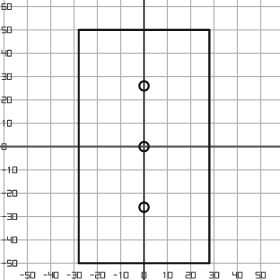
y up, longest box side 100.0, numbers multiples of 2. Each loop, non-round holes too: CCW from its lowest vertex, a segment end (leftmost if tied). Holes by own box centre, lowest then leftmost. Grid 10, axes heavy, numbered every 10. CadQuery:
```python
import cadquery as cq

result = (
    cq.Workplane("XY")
    .moveTo(-28.0, -50.0)
    .lineTo(28.0, -50.0)
    .lineTo(28.0, 50.0)
    .lineTo(-28.0, 50.0)
    .close()
    .moveTo(0.0, -26.0)
    .circle(2.0)
    .moveTo(0.0, 0.0)
    .circle(2.0)
    .moveTo(0.0, 26.0)
    .circle(2.0)
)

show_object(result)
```